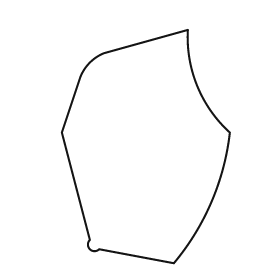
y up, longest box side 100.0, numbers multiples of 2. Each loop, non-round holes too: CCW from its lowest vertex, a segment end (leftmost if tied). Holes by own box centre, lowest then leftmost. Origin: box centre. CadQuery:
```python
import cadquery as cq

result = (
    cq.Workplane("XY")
    .moveTo(12.0, -50.0)
    .threePointArc((28.0, -24.0), (36.0, 6.0))
    .threePointArc((22.0, 26.0), (18.0, 50.0))
    .lineTo(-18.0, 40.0)
    .threePointArc((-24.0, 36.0), (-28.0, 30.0))
    .lineTo(-36.0, 6.0)
    .lineTo(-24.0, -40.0)
    .threePointArc((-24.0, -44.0), (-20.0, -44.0))
    .close()
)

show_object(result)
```